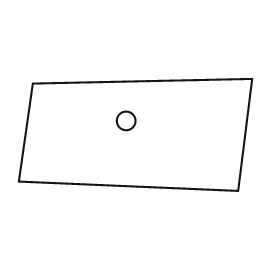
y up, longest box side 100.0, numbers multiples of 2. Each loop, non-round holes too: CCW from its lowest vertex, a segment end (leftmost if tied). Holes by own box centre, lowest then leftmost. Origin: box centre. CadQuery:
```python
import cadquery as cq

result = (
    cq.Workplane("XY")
    .moveTo(44.0, -24.0)
    .lineTo(50.0, 24.0)
    .lineTo(-44.0, 22.0)
    .lineTo(-50.0, -20.0)
    .close()
    .moveTo(-4.0, 6.0)
    .circle(4.0)
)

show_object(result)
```